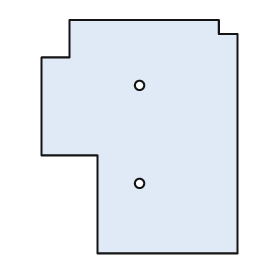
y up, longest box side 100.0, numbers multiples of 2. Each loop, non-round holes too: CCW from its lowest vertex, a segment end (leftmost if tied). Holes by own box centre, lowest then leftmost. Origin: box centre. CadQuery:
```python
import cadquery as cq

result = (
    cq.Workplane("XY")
    .moveTo(-18.0, -50.0)
    .lineTo(42.0, -50.0)
    .lineTo(42.0, 44.0)
    .lineTo(34.0, 44.0)
    .lineTo(34.0, 50.0)
    .lineTo(-30.0, 50.0)
    .lineTo(-30.0, 34.0)
    .lineTo(-42.0, 34.0)
    .lineTo(-42.0, -8.0)
    .lineTo(-18.0, -8.0)
    .close()
    .moveTo(0.0, -20.0)
    .circle(2.0)
    .moveTo(0.0, 22.0)
    .circle(2.0)
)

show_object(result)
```